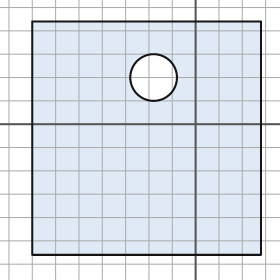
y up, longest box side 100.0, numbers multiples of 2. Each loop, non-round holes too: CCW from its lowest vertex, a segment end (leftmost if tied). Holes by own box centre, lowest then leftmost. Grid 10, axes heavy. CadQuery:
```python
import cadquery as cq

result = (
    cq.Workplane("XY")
    .moveTo(-70.0, -56.0)
    .lineTo(28.0, -56.0)
    .lineTo(28.0, 44.0)
    .lineTo(-70.0, 44.0)
    .close()
    .moveTo(-18.0, 20.0)
    .circle(10.0)
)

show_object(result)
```